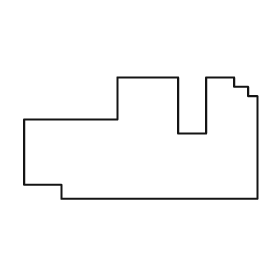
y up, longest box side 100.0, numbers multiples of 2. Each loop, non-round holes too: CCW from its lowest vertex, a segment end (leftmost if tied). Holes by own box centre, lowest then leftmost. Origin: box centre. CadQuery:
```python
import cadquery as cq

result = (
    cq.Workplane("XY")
    .moveTo(-34.0, -26.0)
    .lineTo(50.0, -26.0)
    .lineTo(50.0, 18.0)
    .lineTo(46.0, 18.0)
    .lineTo(46.0, 22.0)
    .lineTo(40.0, 22.0)
    .lineTo(40.0, 26.0)
    .lineTo(28.0, 26.0)
    .lineTo(28.0, 2.0)
    .lineTo(16.0, 2.0)
    .lineTo(16.0, 26.0)
    .lineTo(-10.0, 26.0)
    .lineTo(-10.0, 8.0)
    .lineTo(-50.0, 8.0)
    .lineTo(-50.0, -20.0)
    .lineTo(-34.0, -20.0)
    .close()
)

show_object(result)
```